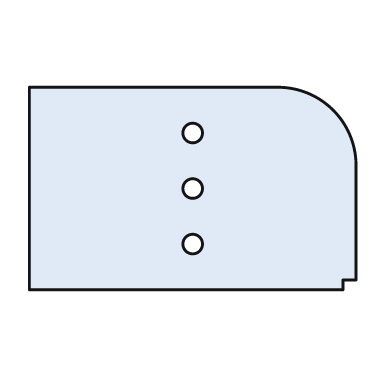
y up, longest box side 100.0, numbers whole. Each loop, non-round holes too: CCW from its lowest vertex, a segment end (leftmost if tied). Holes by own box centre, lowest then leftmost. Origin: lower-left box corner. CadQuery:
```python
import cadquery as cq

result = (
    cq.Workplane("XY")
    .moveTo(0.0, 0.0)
    .lineTo(96.0, 0.0)
    .lineTo(96.0, 3.0)
    .lineTo(100.0, 3.0)
    .lineTo(100.0, 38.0)
    .threePointArc((93.0, 55.0), (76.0, 62.0))
    .lineTo(0.0, 62.0)
    .close()
    .moveTo(50.0, 14.0)
    .circle(3.0)
    .moveTo(50.0, 31.0)
    .circle(3.0)
    .moveTo(50.0, 48.0)
    .circle(3.0)
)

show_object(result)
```